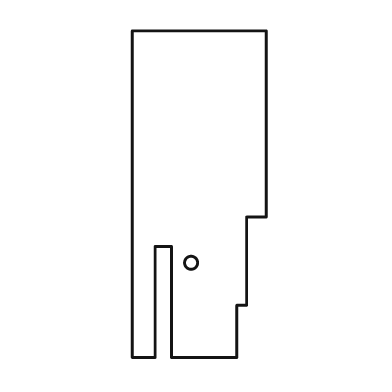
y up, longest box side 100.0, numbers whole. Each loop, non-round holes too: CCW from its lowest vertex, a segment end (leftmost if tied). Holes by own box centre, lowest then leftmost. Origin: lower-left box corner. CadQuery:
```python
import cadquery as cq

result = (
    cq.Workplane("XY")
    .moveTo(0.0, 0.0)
    .lineTo(7.0, 0.0)
    .lineTo(7.0, 34.0)
    .lineTo(12.0, 34.0)
    .lineTo(12.0, 0.0)
    .lineTo(32.0, 0.0)
    .lineTo(32.0, 16.0)
    .lineTo(35.0, 16.0)
    .lineTo(35.0, 43.0)
    .lineTo(41.0, 43.0)
    .lineTo(41.0, 100.0)
    .lineTo(0.0, 100.0)
    .close()
    .moveTo(18.0, 29.0)
    .circle(2.0)
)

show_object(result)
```